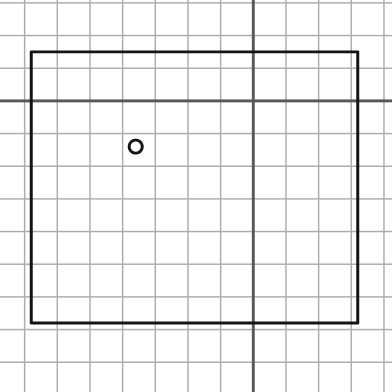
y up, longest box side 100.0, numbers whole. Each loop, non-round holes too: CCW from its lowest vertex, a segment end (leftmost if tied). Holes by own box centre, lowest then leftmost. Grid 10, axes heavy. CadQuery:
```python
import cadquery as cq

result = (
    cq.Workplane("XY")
    .moveTo(-68.0, -68.0)
    .lineTo(32.0, -68.0)
    .lineTo(32.0, 15.0)
    .lineTo(-68.0, 15.0)
    .close()
    .moveTo(-36.0, -14.0)
    .circle(2.0)
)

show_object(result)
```